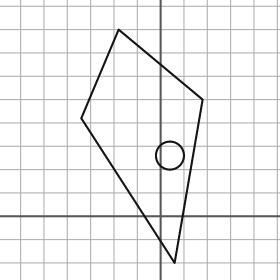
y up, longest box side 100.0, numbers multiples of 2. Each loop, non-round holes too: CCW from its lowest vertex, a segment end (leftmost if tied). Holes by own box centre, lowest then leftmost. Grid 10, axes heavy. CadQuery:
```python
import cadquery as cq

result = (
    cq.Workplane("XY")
    .moveTo(6.0, -20.0)
    .lineTo(18.0, 50.0)
    .lineTo(-18.0, 80.0)
    .lineTo(-34.0, 42.0)
    .close()
    .moveTo(4.0, 26.0)
    .circle(6.0)
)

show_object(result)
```